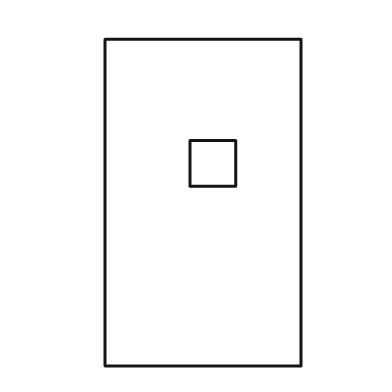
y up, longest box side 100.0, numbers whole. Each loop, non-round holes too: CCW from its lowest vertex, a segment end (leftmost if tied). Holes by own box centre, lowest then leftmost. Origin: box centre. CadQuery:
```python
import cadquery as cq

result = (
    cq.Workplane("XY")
    .moveTo(-30.0, -50.0)
    .lineTo(30.0, -50.0)
    .lineTo(30.0, 50.0)
    .lineTo(-30.0, 50.0)
    .close()
    .moveTo(-4.0, 5.0)
    .lineTo(10.0, 5.0)
    .lineTo(10.0, 19.0)
    .lineTo(-4.0, 19.0)
    .close()
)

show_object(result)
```